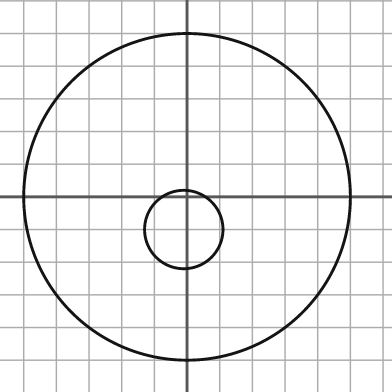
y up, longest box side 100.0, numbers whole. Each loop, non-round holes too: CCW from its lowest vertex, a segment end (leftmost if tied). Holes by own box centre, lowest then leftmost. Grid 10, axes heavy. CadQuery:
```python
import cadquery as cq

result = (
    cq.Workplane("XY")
    .moveTo(0.0, 0.0)
    .circle(50.0)
    .moveTo(-1.0, -10.0)
    .circle(12.0)
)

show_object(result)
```